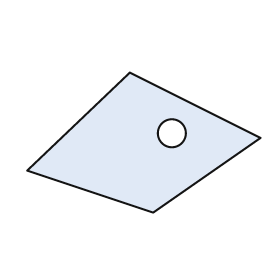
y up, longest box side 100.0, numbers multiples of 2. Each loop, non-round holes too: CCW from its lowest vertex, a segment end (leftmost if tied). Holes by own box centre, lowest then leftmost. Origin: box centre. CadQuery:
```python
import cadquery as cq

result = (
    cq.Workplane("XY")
    .moveTo(4.0, -30.0)
    .lineTo(50.0, 2.0)
    .lineTo(-6.0, 30.0)
    .lineTo(-50.0, -12.0)
    .close()
    .moveTo(12.0, 4.0)
    .circle(6.0)
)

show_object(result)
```